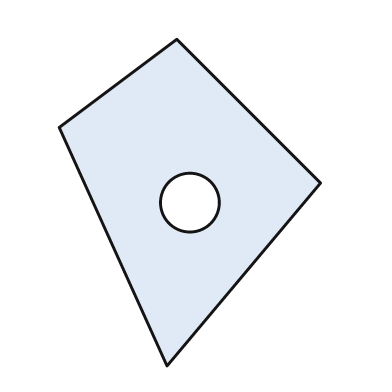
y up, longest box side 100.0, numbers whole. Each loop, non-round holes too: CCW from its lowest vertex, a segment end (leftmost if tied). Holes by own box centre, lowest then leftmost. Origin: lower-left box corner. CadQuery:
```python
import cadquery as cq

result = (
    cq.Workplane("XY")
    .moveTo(33.0, 0.0)
    .lineTo(80.0, 56.0)
    .lineTo(36.0, 100.0)
    .lineTo(0.0, 73.0)
    .close()
    .moveTo(40.0, 50.0)
    .circle(9.0)
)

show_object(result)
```